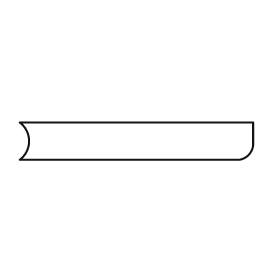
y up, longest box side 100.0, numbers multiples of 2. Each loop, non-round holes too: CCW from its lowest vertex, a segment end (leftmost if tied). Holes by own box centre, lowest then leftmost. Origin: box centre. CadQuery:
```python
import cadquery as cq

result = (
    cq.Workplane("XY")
    .moveTo(-50.0, -8.0)
    .lineTo(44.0, -8.0)
    .threePointArc((48.0, -6.0), (50.0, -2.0))
    .lineTo(50.0, 8.0)
    .lineTo(-50.0, 8.0)
    .threePointArc((-46.0, 0.0), (-50.0, -8.0))
    .close()
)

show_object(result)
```